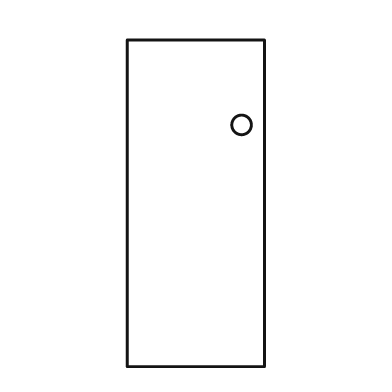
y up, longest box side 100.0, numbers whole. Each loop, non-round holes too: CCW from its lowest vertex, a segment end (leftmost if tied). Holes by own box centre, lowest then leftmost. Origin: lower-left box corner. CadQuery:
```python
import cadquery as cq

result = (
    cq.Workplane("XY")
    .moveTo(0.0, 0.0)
    .lineTo(42.0, 0.0)
    .lineTo(42.0, 100.0)
    .lineTo(0.0, 100.0)
    .close()
    .moveTo(35.0, 74.0)
    .circle(3.0)
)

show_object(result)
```